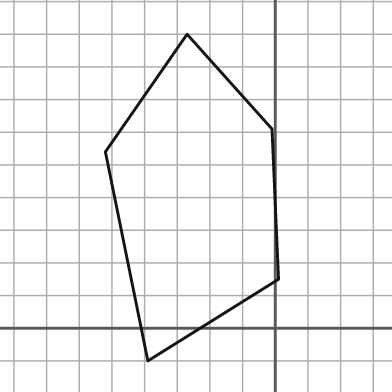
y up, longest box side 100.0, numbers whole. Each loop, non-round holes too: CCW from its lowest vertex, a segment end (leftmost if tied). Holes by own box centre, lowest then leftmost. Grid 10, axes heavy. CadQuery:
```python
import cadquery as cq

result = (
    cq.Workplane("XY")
    .moveTo(-39.0, -10.0)
    .lineTo(1.0, 15.0)
    .lineTo(-1.0, 61.0)
    .lineTo(-27.0, 90.0)
    .lineTo(-52.0, 54.0)
    .close()
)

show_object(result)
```